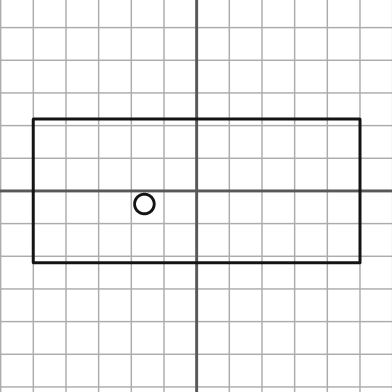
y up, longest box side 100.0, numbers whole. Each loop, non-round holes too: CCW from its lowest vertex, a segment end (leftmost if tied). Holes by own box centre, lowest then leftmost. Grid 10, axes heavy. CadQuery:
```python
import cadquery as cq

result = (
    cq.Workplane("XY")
    .moveTo(-50.0, -22.0)
    .lineTo(50.0, -22.0)
    .lineTo(50.0, 22.0)
    .lineTo(-50.0, 22.0)
    .close()
    .moveTo(-16.0, -4.0)
    .circle(3.0)
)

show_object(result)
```